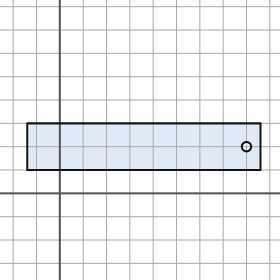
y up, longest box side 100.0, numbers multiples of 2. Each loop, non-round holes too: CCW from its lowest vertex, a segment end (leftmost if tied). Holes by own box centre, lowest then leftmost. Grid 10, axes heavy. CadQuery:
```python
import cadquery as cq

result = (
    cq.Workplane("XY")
    .moveTo(-14.0, 10.0)
    .lineTo(86.0, 10.0)
    .lineTo(86.0, 30.0)
    .lineTo(-14.0, 30.0)
    .close()
    .moveTo(80.0, 20.0)
    .circle(2.0)
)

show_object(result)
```